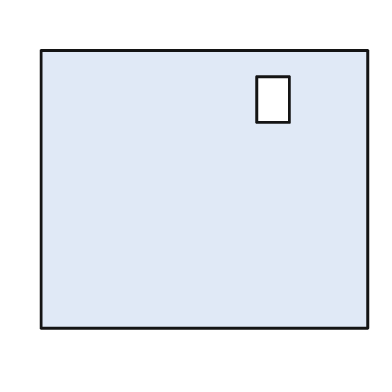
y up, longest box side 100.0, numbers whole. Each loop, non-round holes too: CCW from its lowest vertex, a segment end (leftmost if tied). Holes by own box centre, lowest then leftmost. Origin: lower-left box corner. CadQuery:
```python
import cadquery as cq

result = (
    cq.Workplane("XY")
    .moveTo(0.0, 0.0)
    .lineTo(100.0, 0.0)
    .lineTo(100.0, 85.0)
    .lineTo(0.0, 85.0)
    .close()
    .moveTo(66.0, 63.0)
    .lineTo(76.0, 63.0)
    .lineTo(76.0, 77.0)
    .lineTo(66.0, 77.0)
    .close()
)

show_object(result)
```